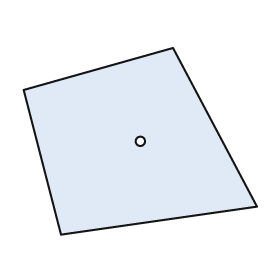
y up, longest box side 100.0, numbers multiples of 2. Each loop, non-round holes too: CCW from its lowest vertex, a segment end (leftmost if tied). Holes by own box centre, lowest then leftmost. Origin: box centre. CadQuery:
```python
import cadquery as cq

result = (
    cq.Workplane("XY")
    .moveTo(-34.0, -40.0)
    .lineTo(50.0, -28.0)
    .lineTo(14.0, 40.0)
    .lineTo(-50.0, 22.0)
    .close()
    .moveTo(0.0, 0.0)
    .circle(2.0)
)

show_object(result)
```